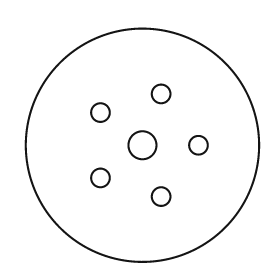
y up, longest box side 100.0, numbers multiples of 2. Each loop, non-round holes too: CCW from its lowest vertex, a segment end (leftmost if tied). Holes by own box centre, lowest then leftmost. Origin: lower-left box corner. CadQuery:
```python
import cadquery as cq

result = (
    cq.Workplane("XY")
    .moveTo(50.0, 50.0)
    .circle(50.0)
    .moveTo(58.0, 28.0)
    .circle(4.0)
    .moveTo(32.0, 36.0)
    .circle(4.0)
    .moveTo(50.0, 50.0)
    .circle(6.0)
    .moveTo(74.0, 50.0)
    .circle(4.0)
    .moveTo(32.0, 64.0)
    .circle(4.0)
    .moveTo(58.0, 72.0)
    .circle(4.0)
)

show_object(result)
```